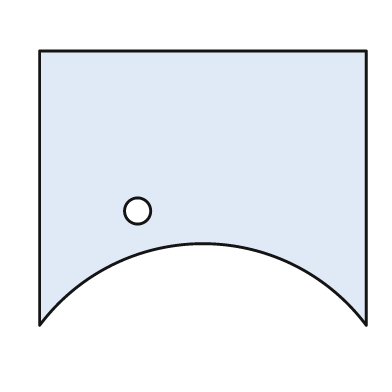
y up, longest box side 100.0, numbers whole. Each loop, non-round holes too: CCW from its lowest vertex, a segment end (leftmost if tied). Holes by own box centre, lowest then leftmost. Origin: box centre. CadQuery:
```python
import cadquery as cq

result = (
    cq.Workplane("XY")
    .moveTo(-50.0, -42.0)
    .threePointArc((0.0, -17.0), (50.0, -42.0))
    .lineTo(50.0, 42.0)
    .lineTo(-50.0, 42.0)
    .close()
    .moveTo(-20.0, -7.0)
    .circle(4.0)
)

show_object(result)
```